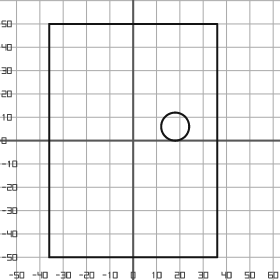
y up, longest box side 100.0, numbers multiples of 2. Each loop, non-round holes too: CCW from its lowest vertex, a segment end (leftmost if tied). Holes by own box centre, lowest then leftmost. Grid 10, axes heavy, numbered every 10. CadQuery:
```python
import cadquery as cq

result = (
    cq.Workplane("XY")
    .moveTo(-36.0, -50.0)
    .lineTo(36.0, -50.0)
    .lineTo(36.0, 50.0)
    .lineTo(-36.0, 50.0)
    .close()
    .moveTo(18.0, 6.0)
    .circle(6.0)
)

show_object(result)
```